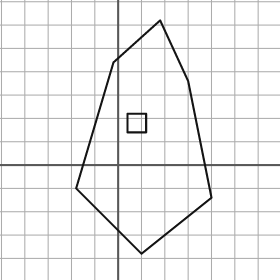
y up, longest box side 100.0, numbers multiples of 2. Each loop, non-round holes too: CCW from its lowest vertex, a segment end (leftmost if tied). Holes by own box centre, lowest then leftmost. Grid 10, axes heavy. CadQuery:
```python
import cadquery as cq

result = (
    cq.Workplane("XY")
    .moveTo(10.0, -38.0)
    .lineTo(40.0, -14.0)
    .lineTo(30.0, 36.0)
    .lineTo(18.0, 62.0)
    .lineTo(-2.0, 44.0)
    .lineTo(-18.0, -10.0)
    .close()
    .moveTo(4.0, 14.0)
    .lineTo(12.0, 14.0)
    .lineTo(12.0, 22.0)
    .lineTo(4.0, 22.0)
    .close()
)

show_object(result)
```